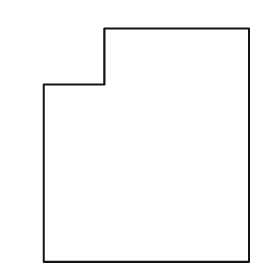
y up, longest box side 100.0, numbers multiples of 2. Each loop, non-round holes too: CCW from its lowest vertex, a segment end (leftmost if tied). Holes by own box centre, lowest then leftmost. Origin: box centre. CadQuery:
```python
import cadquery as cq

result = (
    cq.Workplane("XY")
    .moveTo(-44.0, -50.0)
    .lineTo(44.0, -50.0)
    .lineTo(44.0, 50.0)
    .lineTo(-18.0, 50.0)
    .lineTo(-18.0, 26.0)
    .lineTo(-44.0, 26.0)
    .close()
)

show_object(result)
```